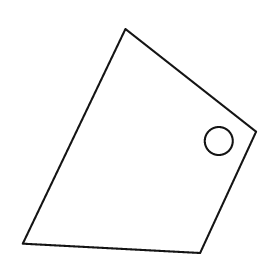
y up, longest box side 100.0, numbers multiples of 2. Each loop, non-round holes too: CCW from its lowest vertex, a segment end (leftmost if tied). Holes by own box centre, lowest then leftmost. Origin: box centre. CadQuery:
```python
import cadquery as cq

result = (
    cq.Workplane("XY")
    .moveTo(26.0, -48.0)
    .lineTo(50.0, 4.0)
    .lineTo(-6.0, 48.0)
    .lineTo(-50.0, -44.0)
    .close()
    .moveTo(34.0, 0.0)
    .circle(6.0)
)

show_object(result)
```